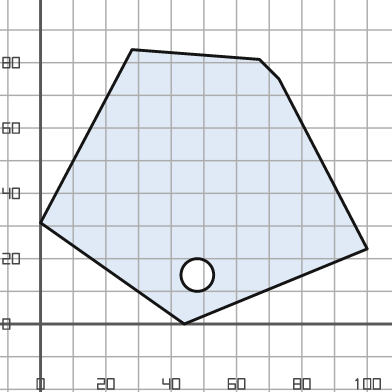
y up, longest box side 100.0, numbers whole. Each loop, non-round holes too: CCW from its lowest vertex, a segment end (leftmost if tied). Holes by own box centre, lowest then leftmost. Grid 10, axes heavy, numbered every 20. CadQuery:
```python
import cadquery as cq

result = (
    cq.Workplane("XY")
    .moveTo(44.0, 0.0)
    .lineTo(100.0, 23.0)
    .lineTo(73.0, 75.0)
    .lineTo(67.0, 81.0)
    .lineTo(28.0, 84.0)
    .lineTo(0.0, 31.0)
    .close()
    .moveTo(48.0, 15.0)
    .circle(5.0)
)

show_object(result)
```